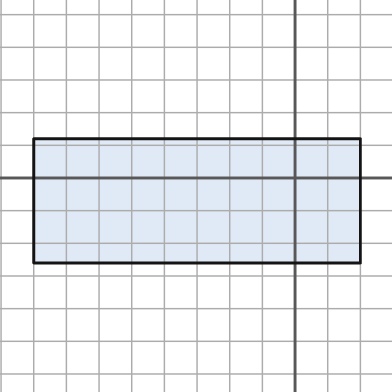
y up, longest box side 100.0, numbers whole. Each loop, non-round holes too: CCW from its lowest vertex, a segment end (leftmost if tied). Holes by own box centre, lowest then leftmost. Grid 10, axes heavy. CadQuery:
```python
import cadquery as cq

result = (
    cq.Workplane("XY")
    .moveTo(-80.0, -26.0)
    .lineTo(20.0, -26.0)
    .lineTo(20.0, 12.0)
    .lineTo(-80.0, 12.0)
    .close()
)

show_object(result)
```